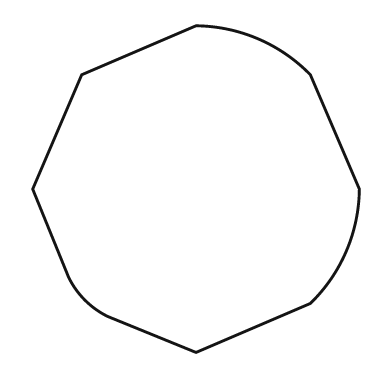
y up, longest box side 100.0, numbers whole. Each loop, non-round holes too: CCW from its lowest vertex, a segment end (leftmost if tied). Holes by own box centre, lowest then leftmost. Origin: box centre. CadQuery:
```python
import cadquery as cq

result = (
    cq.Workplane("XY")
    .moveTo(0.0, -50.0)
    .lineTo(35.0, -35.0)
    .threePointArc((46.0, -19.0), (50.0, 0.0))
    .lineTo(35.0, 35.0)
    .threePointArc((19.0, 46.0), (0.0, 50.0))
    .lineTo(-35.0, 35.0)
    .lineTo(-50.0, 0.0)
    .lineTo(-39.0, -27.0)
    .threePointArc((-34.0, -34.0), (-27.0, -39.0))
    .close()
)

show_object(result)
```